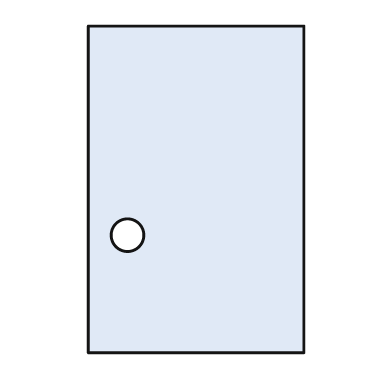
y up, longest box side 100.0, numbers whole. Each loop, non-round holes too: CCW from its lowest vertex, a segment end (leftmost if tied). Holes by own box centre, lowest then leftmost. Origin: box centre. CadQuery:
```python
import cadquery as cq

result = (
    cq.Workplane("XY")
    .moveTo(-33.0, -50.0)
    .lineTo(33.0, -50.0)
    .lineTo(33.0, 50.0)
    .lineTo(-33.0, 50.0)
    .close()
    .moveTo(-21.0, -14.0)
    .circle(5.0)
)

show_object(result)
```